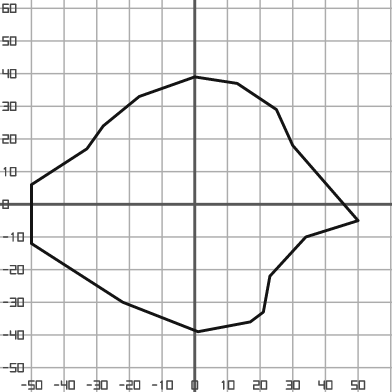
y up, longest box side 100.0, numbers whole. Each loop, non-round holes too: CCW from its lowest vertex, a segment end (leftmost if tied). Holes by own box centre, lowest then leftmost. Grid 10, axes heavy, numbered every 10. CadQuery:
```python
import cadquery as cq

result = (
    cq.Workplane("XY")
    .moveTo(1.0, -39.0)
    .lineTo(17.0, -36.0)
    .lineTo(21.0, -33.0)
    .lineTo(23.0, -22.0)
    .lineTo(34.0, -10.0)
    .lineTo(50.0, -5.0)
    .lineTo(30.0, 18.0)
    .lineTo(25.0, 29.0)
    .lineTo(13.0, 37.0)
    .lineTo(0.0, 39.0)
    .lineTo(-17.0, 33.0)
    .lineTo(-28.0, 24.0)
    .lineTo(-33.0, 17.0)
    .lineTo(-50.0, 6.0)
    .lineTo(-50.0, -12.0)
    .lineTo(-22.0, -30.0)
    .close()
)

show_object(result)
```